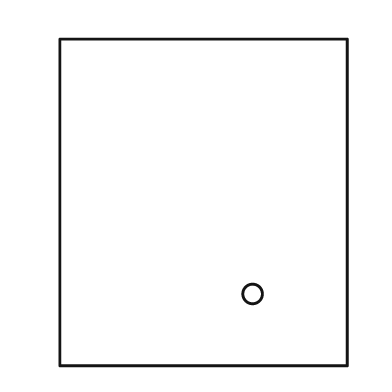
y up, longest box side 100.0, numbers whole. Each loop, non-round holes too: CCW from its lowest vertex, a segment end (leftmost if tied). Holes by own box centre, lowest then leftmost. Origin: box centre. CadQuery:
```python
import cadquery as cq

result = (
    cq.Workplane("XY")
    .moveTo(-44.0, -50.0)
    .lineTo(44.0, -50.0)
    .lineTo(44.0, 50.0)
    .lineTo(-44.0, 50.0)
    .close()
    .moveTo(15.0, -28.0)
    .circle(3.0)
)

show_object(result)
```